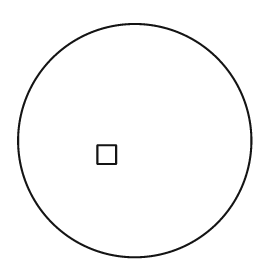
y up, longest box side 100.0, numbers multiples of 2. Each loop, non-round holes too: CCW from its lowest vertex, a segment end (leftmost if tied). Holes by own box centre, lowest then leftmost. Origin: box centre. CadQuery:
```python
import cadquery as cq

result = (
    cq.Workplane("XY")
    .moveTo(0.0, 0.0)
    .circle(50.0)
    .moveTo(-16.0, -10.0)
    .lineTo(-8.0, -10.0)
    .lineTo(-8.0, -2.0)
    .lineTo(-16.0, -2.0)
    .close()
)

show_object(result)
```